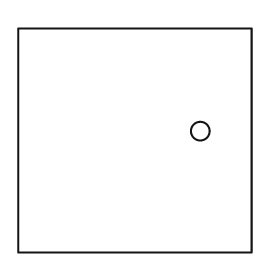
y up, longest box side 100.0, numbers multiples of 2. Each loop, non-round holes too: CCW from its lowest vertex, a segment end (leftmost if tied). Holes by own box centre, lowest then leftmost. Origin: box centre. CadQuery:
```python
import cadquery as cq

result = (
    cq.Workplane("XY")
    .moveTo(-50.0, -48.0)
    .lineTo(50.0, -48.0)
    .lineTo(50.0, 48.0)
    .lineTo(-50.0, 48.0)
    .close()
    .moveTo(28.0, 4.0)
    .circle(4.0)
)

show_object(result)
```